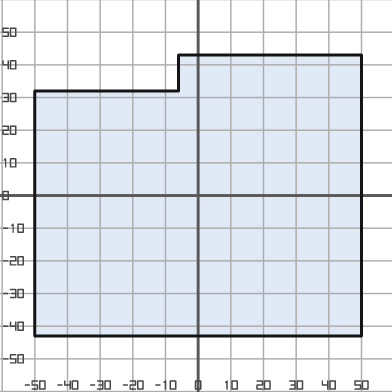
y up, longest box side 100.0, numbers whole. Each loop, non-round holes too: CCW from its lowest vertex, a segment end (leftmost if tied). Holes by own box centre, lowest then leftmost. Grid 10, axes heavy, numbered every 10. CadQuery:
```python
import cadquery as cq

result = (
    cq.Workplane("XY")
    .moveTo(-50.0, -43.0)
    .lineTo(50.0, -43.0)
    .lineTo(50.0, 43.0)
    .lineTo(-6.0, 43.0)
    .lineTo(-6.0, 32.0)
    .lineTo(-50.0, 32.0)
    .close()
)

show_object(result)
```